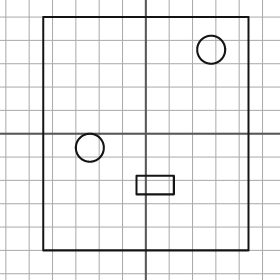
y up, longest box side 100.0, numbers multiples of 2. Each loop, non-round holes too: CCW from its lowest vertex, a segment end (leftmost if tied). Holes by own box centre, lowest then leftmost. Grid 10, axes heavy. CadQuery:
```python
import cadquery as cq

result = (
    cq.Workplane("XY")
    .moveTo(-44.0, -50.0)
    .lineTo(44.0, -50.0)
    .lineTo(44.0, 50.0)
    .lineTo(-44.0, 50.0)
    .close()
    .moveTo(-4.0, -26.0)
    .lineTo(12.0, -26.0)
    .lineTo(12.0, -18.0)
    .lineTo(-4.0, -18.0)
    .close()
    .moveTo(-24.0, -6.0)
    .circle(6.0)
    .moveTo(28.0, 36.0)
    .circle(6.0)
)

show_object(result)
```